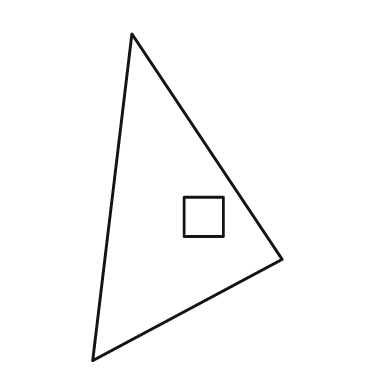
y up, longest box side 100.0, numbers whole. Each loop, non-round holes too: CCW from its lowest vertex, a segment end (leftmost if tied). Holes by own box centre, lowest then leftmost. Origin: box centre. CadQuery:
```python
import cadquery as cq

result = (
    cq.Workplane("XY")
    .moveTo(-29.0, -50.0)
    .lineTo(29.0, -19.0)
    .lineTo(-17.0, 50.0)
    .close()
    .moveTo(-1.0, -12.0)
    .lineTo(11.0, -12.0)
    .lineTo(11.0, 0.0)
    .lineTo(-1.0, 0.0)
    .close()
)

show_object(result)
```